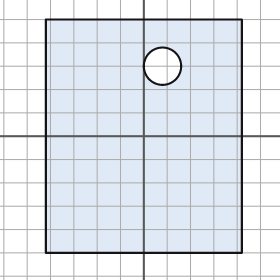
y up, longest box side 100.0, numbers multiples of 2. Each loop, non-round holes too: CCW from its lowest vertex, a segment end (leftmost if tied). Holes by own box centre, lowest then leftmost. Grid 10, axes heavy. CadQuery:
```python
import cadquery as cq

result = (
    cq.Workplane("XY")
    .moveTo(-42.0, -50.0)
    .lineTo(42.0, -50.0)
    .lineTo(42.0, 50.0)
    .lineTo(-42.0, 50.0)
    .close()
    .moveTo(8.0, 30.0)
    .circle(8.0)
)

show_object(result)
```